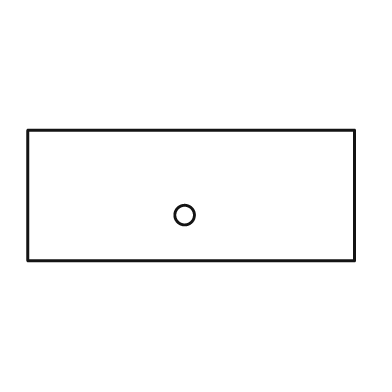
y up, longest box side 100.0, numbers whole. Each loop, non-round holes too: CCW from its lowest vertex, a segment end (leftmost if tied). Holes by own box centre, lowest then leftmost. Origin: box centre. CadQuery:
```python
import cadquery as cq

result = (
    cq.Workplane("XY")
    .moveTo(-50.0, -20.0)
    .lineTo(50.0, -20.0)
    .lineTo(50.0, 20.0)
    .lineTo(-50.0, 20.0)
    .close()
    .moveTo(-2.0, -6.0)
    .circle(3.0)
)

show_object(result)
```